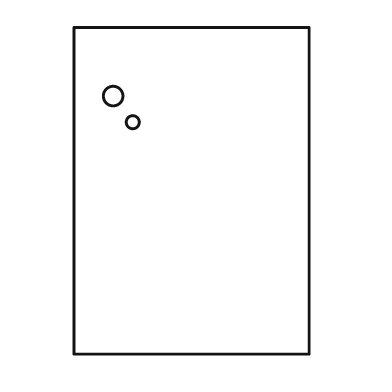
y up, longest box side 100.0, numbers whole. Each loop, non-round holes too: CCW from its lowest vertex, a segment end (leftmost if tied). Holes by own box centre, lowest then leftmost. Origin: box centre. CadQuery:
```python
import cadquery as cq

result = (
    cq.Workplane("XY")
    .moveTo(-36.0, -50.0)
    .lineTo(36.0, -50.0)
    .lineTo(36.0, 50.0)
    .lineTo(-36.0, 50.0)
    .close()
    .moveTo(-18.0, 21.0)
    .circle(2.0)
    .moveTo(-24.0, 29.0)
    .circle(3.0)
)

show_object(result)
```